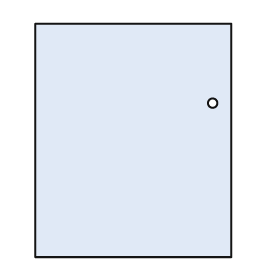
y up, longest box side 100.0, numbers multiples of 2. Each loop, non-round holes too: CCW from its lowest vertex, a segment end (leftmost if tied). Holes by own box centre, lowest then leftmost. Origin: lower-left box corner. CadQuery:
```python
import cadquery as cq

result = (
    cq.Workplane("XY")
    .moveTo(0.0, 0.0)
    .lineTo(84.0, 0.0)
    .lineTo(84.0, 100.0)
    .lineTo(0.0, 100.0)
    .close()
    .moveTo(76.0, 66.0)
    .circle(2.0)
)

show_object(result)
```